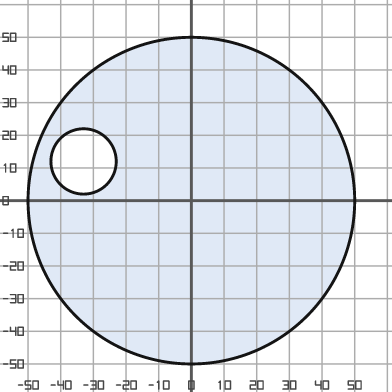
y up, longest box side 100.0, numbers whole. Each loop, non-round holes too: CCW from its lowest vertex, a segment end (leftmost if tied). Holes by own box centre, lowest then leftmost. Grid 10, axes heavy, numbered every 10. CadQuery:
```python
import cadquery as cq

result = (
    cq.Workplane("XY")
    .moveTo(0.0, 0.0)
    .circle(50.0)
    .moveTo(-33.0, 12.0)
    .circle(10.0)
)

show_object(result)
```